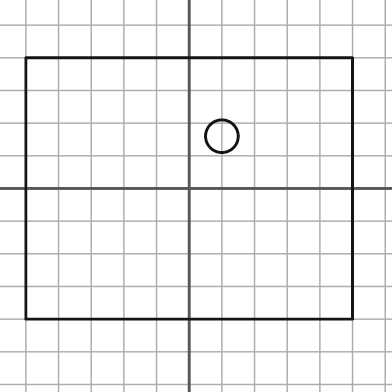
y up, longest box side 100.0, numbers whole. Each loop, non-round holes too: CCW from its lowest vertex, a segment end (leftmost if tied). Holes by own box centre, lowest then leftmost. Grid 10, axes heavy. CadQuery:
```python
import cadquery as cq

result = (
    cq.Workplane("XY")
    .moveTo(-50.0, -40.0)
    .lineTo(50.0, -40.0)
    .lineTo(50.0, 40.0)
    .lineTo(-50.0, 40.0)
    .close()
    .moveTo(10.0, 16.0)
    .circle(5.0)
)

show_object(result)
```